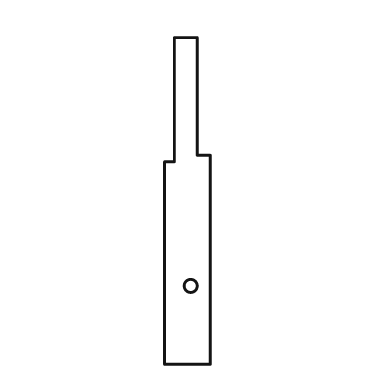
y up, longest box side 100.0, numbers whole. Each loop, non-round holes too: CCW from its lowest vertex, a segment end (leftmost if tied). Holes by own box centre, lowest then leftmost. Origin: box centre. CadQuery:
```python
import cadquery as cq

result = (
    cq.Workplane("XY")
    .moveTo(-7.0, -50.0)
    .lineTo(7.0, -50.0)
    .lineTo(7.0, 14.0)
    .lineTo(3.0, 14.0)
    .lineTo(3.0, 50.0)
    .lineTo(-4.0, 50.0)
    .lineTo(-4.0, 12.0)
    .lineTo(-7.0, 12.0)
    .close()
    .moveTo(1.0, -26.0)
    .circle(2.0)
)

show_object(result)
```